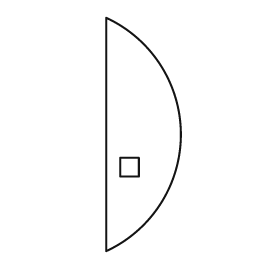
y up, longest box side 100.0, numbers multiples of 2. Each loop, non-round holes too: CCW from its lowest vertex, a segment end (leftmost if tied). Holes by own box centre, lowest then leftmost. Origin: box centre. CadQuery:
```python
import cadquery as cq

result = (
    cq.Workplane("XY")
    .moveTo(-16.0, -50.0)
    .threePointArc((16.0, 0.0), (-16.0, 50.0))
    .close()
    .moveTo(-10.0, -18.0)
    .lineTo(-2.0, -18.0)
    .lineTo(-2.0, -10.0)
    .lineTo(-10.0, -10.0)
    .close()
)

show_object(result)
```